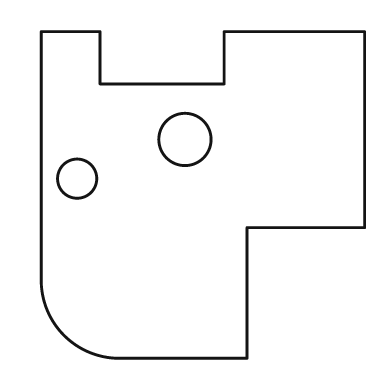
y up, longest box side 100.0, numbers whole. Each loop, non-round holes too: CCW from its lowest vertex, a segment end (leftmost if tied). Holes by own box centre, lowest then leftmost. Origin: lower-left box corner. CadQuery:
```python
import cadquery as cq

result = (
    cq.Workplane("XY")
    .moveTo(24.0, 0.0)
    .lineTo(63.0, 0.0)
    .lineTo(63.0, 40.0)
    .lineTo(99.0, 40.0)
    .lineTo(99.0, 100.0)
    .lineTo(56.0, 100.0)
    .lineTo(56.0, 84.0)
    .lineTo(18.0, 84.0)
    .lineTo(18.0, 100.0)
    .lineTo(0.0, 100.0)
    .lineTo(0.0, 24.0)
    .threePointArc((7.0, 7.0), (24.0, 0.0))
    .close()
    .moveTo(11.0, 55.0)
    .circle(6.0)
    .moveTo(44.0, 67.0)
    .circle(8.0)
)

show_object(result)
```